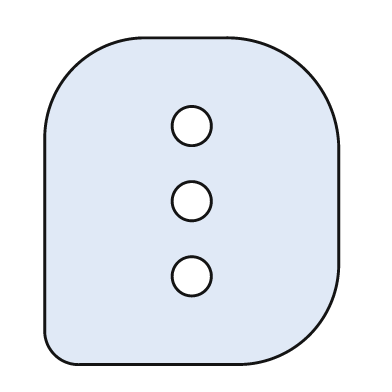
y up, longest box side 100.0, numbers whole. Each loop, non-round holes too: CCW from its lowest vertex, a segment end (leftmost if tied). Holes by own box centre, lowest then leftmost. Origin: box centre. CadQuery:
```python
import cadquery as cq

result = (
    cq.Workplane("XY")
    .moveTo(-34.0, -50.0)
    .lineTo(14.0, -50.0)
    .threePointArc((36.0, -41.0), (45.0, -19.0))
    .lineTo(45.0, 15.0)
    .threePointArc((35.0, 40.0), (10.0, 50.0))
    .lineTo(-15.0, 50.0)
    .threePointArc((-36.0, 41.0), (-45.0, 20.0))
    .lineTo(-45.0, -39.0)
    .threePointArc((-42.0, -47.0), (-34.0, -50.0))
    .close()
    .moveTo(0.0, -23.0)
    .circle(6.0)
    .moveTo(0.0, 0.0)
    .circle(6.0)
    .moveTo(0.0, 23.0)
    .circle(6.0)
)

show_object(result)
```